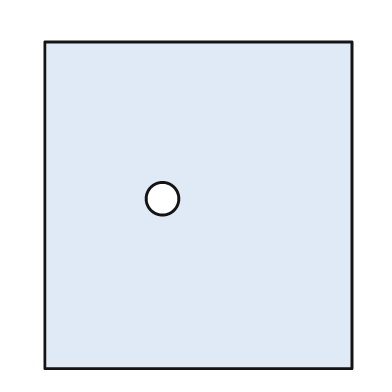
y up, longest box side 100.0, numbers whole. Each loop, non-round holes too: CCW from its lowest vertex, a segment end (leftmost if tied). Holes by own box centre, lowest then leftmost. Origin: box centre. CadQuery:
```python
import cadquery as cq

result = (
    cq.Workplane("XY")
    .moveTo(-47.0, -50.0)
    .lineTo(47.0, -50.0)
    .lineTo(47.0, 50.0)
    .lineTo(-47.0, 50.0)
    .close()
    .moveTo(-11.0, 2.0)
    .circle(5.0)
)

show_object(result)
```